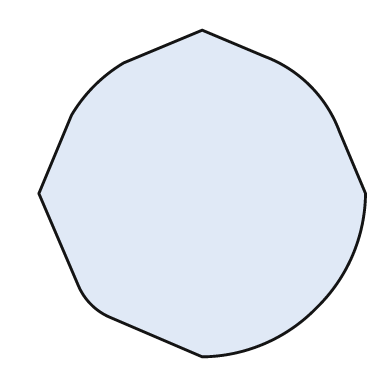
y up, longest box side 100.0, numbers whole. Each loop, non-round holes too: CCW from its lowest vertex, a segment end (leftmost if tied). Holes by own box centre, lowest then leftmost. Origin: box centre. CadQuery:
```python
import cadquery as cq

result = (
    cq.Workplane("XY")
    .moveTo(0.0, -50.0)
    .threePointArc((19.0, -46.0), (35.0, -35.0))
    .threePointArc((46.0, -19.0), (50.0, 0.0))
    .lineTo(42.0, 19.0)
    .threePointArc((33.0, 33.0), (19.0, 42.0))
    .lineTo(0.0, 50.0)
    .lineTo(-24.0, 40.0)
    .threePointArc((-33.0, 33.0), (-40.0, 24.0))
    .lineTo(-50.0, 0.0)
    .lineTo(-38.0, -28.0)
    .threePointArc((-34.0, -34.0), (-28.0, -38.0))
    .close()
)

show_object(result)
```